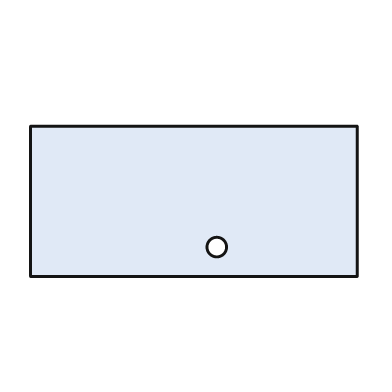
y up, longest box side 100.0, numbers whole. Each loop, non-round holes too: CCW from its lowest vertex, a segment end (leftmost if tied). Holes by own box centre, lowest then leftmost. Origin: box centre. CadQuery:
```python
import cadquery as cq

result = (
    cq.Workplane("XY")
    .moveTo(-50.0, -23.0)
    .lineTo(50.0, -23.0)
    .lineTo(50.0, 23.0)
    .lineTo(-50.0, 23.0)
    .close()
    .moveTo(7.0, -14.0)
    .circle(3.0)
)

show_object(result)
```